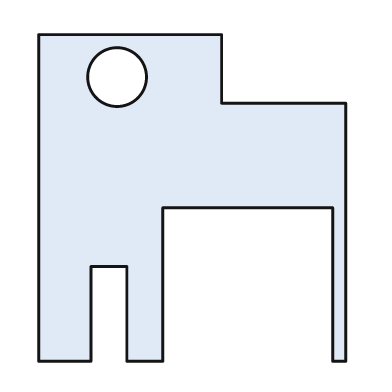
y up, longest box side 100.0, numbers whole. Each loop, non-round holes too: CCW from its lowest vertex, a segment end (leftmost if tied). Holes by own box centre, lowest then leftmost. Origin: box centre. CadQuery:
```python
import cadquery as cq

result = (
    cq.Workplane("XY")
    .moveTo(-47.0, -50.0)
    .lineTo(-31.0, -50.0)
    .lineTo(-31.0, -21.0)
    .lineTo(-20.0, -21.0)
    .lineTo(-20.0, -50.0)
    .lineTo(-9.0, -50.0)
    .lineTo(-9.0, -3.0)
    .lineTo(43.0, -3.0)
    .lineTo(43.0, -50.0)
    .lineTo(47.0, -50.0)
    .lineTo(47.0, 29.0)
    .lineTo(9.0, 29.0)
    .lineTo(9.0, 50.0)
    .lineTo(-47.0, 50.0)
    .close()
    .moveTo(-23.0, 37.0)
    .circle(9.0)
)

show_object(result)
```